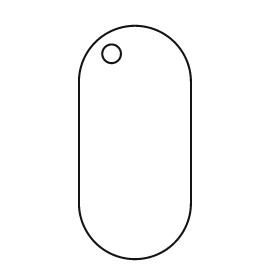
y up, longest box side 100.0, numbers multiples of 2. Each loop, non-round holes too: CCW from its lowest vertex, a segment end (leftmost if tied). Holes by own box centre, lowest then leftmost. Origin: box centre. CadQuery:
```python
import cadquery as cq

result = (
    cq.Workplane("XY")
    .moveTo(-24.0, -26.0)
    .threePointArc((0.0, -50.0), (24.0, -26.0))
    .lineTo(24.0, 26.0)
    .threePointArc((0.0, 50.0), (-24.0, 26.0))
    .close()
    .moveTo(-10.0, 38.0)
    .circle(4.0)
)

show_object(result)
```